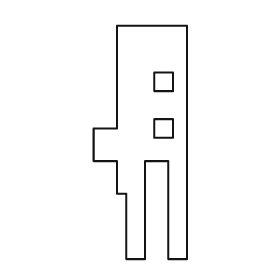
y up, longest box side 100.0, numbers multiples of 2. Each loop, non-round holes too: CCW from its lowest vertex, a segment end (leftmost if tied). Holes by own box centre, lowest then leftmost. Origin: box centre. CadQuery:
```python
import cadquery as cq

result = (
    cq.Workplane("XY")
    .moveTo(-6.0, -50.0)
    .lineTo(2.0, -50.0)
    .lineTo(2.0, -8.0)
    .lineTo(12.0, -8.0)
    .lineTo(12.0, -50.0)
    .lineTo(20.0, -50.0)
    .lineTo(20.0, 50.0)
    .lineTo(-10.0, 50.0)
    .lineTo(-10.0, 6.0)
    .lineTo(-20.0, 6.0)
    .lineTo(-20.0, -8.0)
    .lineTo(-10.0, -8.0)
    .lineTo(-10.0, -22.0)
    .lineTo(-6.0, -22.0)
    .close()
    .moveTo(6.0, 2.0)
    .lineTo(14.0, 2.0)
    .lineTo(14.0, 10.0)
    .lineTo(6.0, 10.0)
    .close()
    .moveTo(6.0, 22.0)
    .lineTo(14.0, 22.0)
    .lineTo(14.0, 30.0)
    .lineTo(6.0, 30.0)
    .close()
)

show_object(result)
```